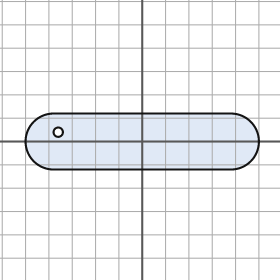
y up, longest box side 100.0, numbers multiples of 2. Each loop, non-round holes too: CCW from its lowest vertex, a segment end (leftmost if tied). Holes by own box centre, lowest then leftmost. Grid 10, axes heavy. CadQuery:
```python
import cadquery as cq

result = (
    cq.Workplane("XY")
    .moveTo(-38.0, -12.0)
    .lineTo(38.0, -12.0)
    .threePointArc((50.0, 0.0), (38.0, 12.0))
    .lineTo(-38.0, 12.0)
    .threePointArc((-50.0, 0.0), (-38.0, -12.0))
    .close()
    .moveTo(-36.0, 4.0)
    .circle(2.0)
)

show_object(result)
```